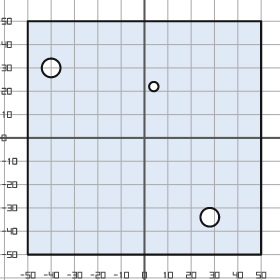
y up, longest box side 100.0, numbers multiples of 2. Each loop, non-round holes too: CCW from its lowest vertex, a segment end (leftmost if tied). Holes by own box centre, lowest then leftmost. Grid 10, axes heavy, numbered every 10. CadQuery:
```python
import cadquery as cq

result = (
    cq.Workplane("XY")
    .moveTo(-50.0, -50.0)
    .lineTo(50.0, -50.0)
    .lineTo(50.0, 50.0)
    .lineTo(-50.0, 50.0)
    .close()
    .moveTo(28.0, -34.0)
    .circle(4.0)
    .moveTo(4.0, 22.0)
    .circle(2.0)
    .moveTo(-40.0, 30.0)
    .circle(4.0)
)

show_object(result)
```